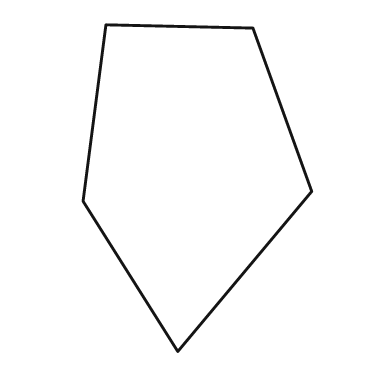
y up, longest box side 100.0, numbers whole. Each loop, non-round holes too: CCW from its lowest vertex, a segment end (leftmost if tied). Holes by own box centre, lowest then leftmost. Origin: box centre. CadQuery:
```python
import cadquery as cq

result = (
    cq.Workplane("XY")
    .moveTo(-6.0, -50.0)
    .lineTo(35.0, -1.0)
    .lineTo(17.0, 49.0)
    .lineTo(-28.0, 50.0)
    .lineTo(-35.0, -4.0)
    .close()
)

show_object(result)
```